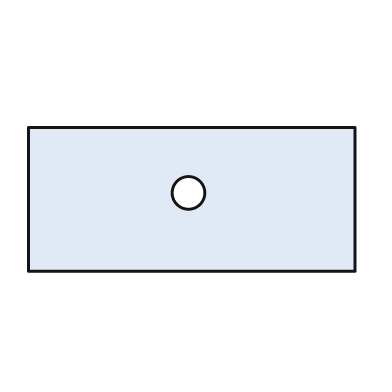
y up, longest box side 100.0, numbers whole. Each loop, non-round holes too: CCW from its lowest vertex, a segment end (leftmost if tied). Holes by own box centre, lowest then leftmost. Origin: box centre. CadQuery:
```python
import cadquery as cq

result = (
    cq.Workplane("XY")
    .moveTo(-50.0, -22.0)
    .lineTo(50.0, -22.0)
    .lineTo(50.0, 22.0)
    .lineTo(-50.0, 22.0)
    .close()
    .moveTo(-1.0, 2.0)
    .circle(5.0)
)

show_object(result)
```